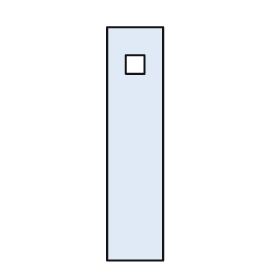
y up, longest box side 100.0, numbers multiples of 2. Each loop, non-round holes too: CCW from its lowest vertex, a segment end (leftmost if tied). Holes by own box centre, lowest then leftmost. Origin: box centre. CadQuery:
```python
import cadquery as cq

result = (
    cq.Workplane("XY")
    .moveTo(-12.0, -50.0)
    .lineTo(12.0, -50.0)
    .lineTo(12.0, 50.0)
    .lineTo(-12.0, 50.0)
    .close()
    .moveTo(-4.0, 30.0)
    .lineTo(4.0, 30.0)
    .lineTo(4.0, 38.0)
    .lineTo(-4.0, 38.0)
    .close()
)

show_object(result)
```